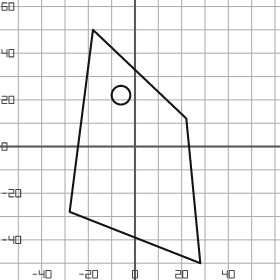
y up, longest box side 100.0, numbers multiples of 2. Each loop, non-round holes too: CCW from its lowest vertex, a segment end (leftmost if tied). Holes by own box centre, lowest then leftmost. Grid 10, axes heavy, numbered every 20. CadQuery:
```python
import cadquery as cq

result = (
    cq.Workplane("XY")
    .moveTo(28.0, -50.0)
    .lineTo(22.0, 12.0)
    .lineTo(-18.0, 50.0)
    .lineTo(-28.0, -28.0)
    .close()
    .moveTo(-6.0, 22.0)
    .circle(4.0)
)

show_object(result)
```